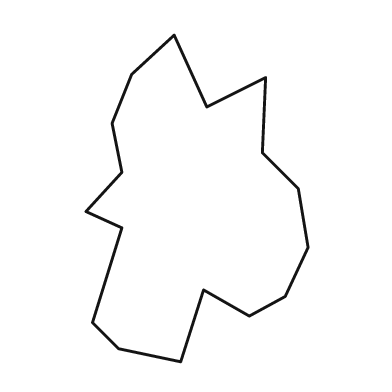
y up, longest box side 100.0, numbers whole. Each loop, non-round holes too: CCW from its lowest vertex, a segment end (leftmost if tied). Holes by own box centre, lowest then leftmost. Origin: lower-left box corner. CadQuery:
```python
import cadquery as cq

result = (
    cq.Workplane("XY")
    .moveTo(29.0, 0.0)
    .lineTo(36.0, 22.0)
    .lineTo(50.0, 14.0)
    .lineTo(61.0, 20.0)
    .lineTo(68.0, 35.0)
    .lineTo(65.0, 53.0)
    .lineTo(54.0, 64.0)
    .lineTo(55.0, 87.0)
    .lineTo(37.0, 78.0)
    .lineTo(27.0, 100.0)
    .lineTo(14.0, 88.0)
    .lineTo(8.0, 73.0)
    .lineTo(11.0, 58.0)
    .lineTo(0.0, 46.0)
    .lineTo(11.0, 41.0)
    .lineTo(2.0, 12.0)
    .lineTo(10.0, 4.0)
    .close()
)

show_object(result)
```